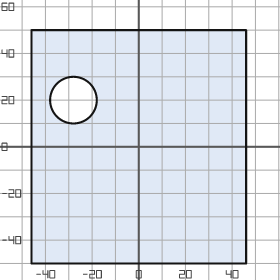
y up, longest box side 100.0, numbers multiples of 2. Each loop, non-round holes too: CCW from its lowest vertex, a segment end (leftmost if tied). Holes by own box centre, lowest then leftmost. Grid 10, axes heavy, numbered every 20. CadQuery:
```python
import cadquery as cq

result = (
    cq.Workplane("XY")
    .moveTo(-46.0, -50.0)
    .lineTo(46.0, -50.0)
    .lineTo(46.0, 50.0)
    .lineTo(-46.0, 50.0)
    .close()
    .moveTo(-28.0, 20.0)
    .circle(10.0)
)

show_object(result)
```